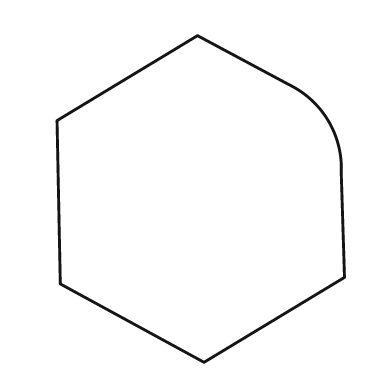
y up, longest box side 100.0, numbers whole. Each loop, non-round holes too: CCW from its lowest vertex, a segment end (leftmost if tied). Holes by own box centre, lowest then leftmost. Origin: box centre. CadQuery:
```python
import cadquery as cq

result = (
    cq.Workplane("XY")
    .moveTo(1.0, -50.0)
    .lineTo(44.0, -24.0)
    .lineTo(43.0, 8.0)
    .threePointArc((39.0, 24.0), (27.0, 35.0))
    .lineTo(-1.0, 50.0)
    .lineTo(-44.0, 24.0)
    .lineTo(-43.0, -26.0)
    .close()
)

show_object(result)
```